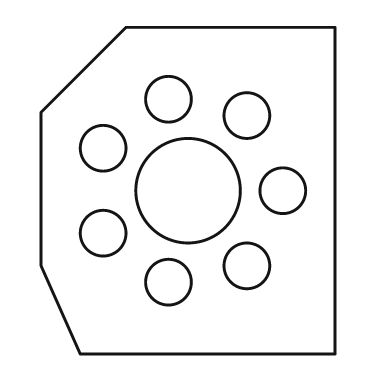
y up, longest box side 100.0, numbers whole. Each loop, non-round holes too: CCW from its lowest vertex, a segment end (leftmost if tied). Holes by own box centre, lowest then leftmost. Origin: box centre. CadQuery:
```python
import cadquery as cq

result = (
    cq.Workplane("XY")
    .moveTo(-33.0, -50.0)
    .lineTo(45.0, -50.0)
    .lineTo(45.0, 50.0)
    .lineTo(-19.0, 50.0)
    .lineTo(-45.0, 24.0)
    .lineTo(-45.0, -23.0)
    .close()
    .moveTo(-6.0, -28.0)
    .circle(7.0)
    .moveTo(18.0, -23.0)
    .circle(7.0)
    .moveTo(-26.0, -13.0)
    .circle(7.0)
    .moveTo(0.0, 0.0)
    .circle(16.0)
    .moveTo(29.0, 0.0)
    .circle(7.0)
    .moveTo(-26.0, 13.0)
    .circle(7.0)
    .moveTo(18.0, 23.0)
    .circle(7.0)
    .moveTo(-6.0, 28.0)
    .circle(7.0)
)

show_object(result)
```